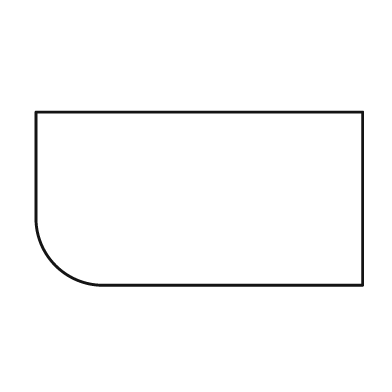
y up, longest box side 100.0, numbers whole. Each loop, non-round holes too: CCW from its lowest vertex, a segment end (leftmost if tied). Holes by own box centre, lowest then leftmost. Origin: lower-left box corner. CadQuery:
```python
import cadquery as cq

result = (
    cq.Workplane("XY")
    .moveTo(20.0, 0.0)
    .lineTo(100.0, 0.0)
    .lineTo(100.0, 53.0)
    .lineTo(0.0, 53.0)
    .lineTo(0.0, 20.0)
    .threePointArc((6.0, 6.0), (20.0, 0.0))
    .close()
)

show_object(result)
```